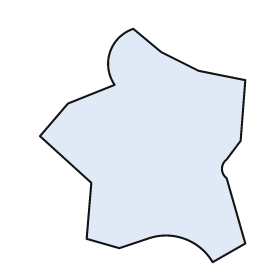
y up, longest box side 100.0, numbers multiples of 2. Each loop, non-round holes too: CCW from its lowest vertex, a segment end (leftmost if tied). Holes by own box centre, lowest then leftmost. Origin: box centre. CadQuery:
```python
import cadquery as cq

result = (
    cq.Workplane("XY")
    .moveTo(30.0, -50.0)
    .lineTo(44.0, -42.0)
    .lineTo(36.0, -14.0)
    .threePointArc((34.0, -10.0), (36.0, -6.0))
    .lineTo(42.0, 2.0)
    .lineTo(44.0, 28.0)
    .lineTo(24.0, 32.0)
    .lineTo(8.0, 40.0)
    .lineTo(-4.0, 50.0)
    .threePointArc((-14.0, 40.0), (-12.0, 26.0))
    .lineTo(-32.0, 18.0)
    .lineTo(-44.0, 4.0)
    .lineTo(-22.0, -16.0)
    .lineTo(-24.0, -40.0)
    .lineTo(-10.0, -44.0)
    .lineTo(2.0, -40.0)
    .threePointArc((18.0, -40.0), (30.0, -50.0))
    .close()
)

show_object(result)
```